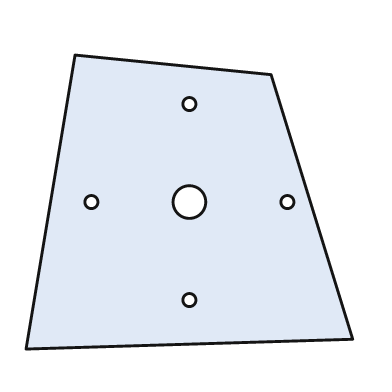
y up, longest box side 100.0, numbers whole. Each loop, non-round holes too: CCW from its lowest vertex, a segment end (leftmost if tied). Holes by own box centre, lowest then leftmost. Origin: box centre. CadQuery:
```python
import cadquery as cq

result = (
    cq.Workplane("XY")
    .moveTo(-50.0, -45.0)
    .lineTo(50.0, -42.0)
    .lineTo(25.0, 39.0)
    .lineTo(-35.0, 45.0)
    .close()
    .moveTo(0.0, -30.0)
    .circle(2.0)
    .moveTo(-30.0, 0.0)
    .circle(2.0)
    .moveTo(0.0, 0.0)
    .circle(5.0)
    .moveTo(30.0, 0.0)
    .circle(2.0)
    .moveTo(0.0, 30.0)
    .circle(2.0)
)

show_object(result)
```